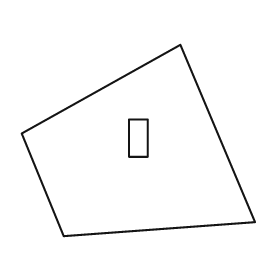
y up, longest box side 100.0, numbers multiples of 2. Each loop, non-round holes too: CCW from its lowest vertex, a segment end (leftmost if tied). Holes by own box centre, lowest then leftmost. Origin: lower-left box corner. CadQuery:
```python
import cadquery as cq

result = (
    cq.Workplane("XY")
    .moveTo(18.0, 0.0)
    .lineTo(100.0, 6.0)
    .lineTo(68.0, 82.0)
    .lineTo(0.0, 44.0)
    .close()
    .moveTo(46.0, 34.0)
    .lineTo(54.0, 34.0)
    .lineTo(54.0, 50.0)
    .lineTo(46.0, 50.0)
    .close()
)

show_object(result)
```